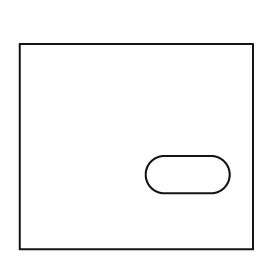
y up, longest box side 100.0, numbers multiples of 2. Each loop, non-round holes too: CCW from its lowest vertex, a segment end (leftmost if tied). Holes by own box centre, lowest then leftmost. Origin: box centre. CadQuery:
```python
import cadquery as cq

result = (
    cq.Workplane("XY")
    .moveTo(-50.0, -44.0)
    .lineTo(50.0, -44.0)
    .lineTo(50.0, 44.0)
    .lineTo(-50.0, 44.0)
    .close()
    .moveTo(12.0, -20.0)
    .lineTo(32.0, -20.0)
    .threePointArc((40.0, -12.0), (32.0, -4.0))
    .lineTo(12.0, -4.0)
    .threePointArc((4.0, -12.0), (12.0, -20.0))
    .close()
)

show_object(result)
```